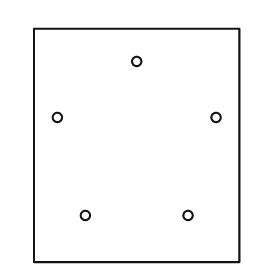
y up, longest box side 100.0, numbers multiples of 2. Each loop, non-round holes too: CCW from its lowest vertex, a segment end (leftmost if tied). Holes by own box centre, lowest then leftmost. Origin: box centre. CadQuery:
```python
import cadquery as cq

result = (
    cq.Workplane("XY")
    .moveTo(-44.0, -50.0)
    .lineTo(44.0, -50.0)
    .lineTo(44.0, 50.0)
    .lineTo(-44.0, 50.0)
    .close()
    .moveTo(-22.0, -30.0)
    .circle(2.0)
    .moveTo(22.0, -30.0)
    .circle(2.0)
    .moveTo(-34.0, 12.0)
    .circle(2.0)
    .moveTo(34.0, 12.0)
    .circle(2.0)
    .moveTo(0.0, 36.0)
    .circle(2.0)
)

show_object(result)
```